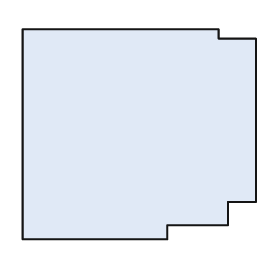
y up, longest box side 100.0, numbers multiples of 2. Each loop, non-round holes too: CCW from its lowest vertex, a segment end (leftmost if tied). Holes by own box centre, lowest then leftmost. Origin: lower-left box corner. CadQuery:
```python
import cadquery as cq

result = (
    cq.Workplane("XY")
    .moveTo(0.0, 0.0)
    .lineTo(62.0, 0.0)
    .lineTo(62.0, 6.0)
    .lineTo(88.0, 6.0)
    .lineTo(88.0, 16.0)
    .lineTo(100.0, 16.0)
    .lineTo(100.0, 86.0)
    .lineTo(84.0, 86.0)
    .lineTo(84.0, 90.0)
    .lineTo(0.0, 90.0)
    .close()
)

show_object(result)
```